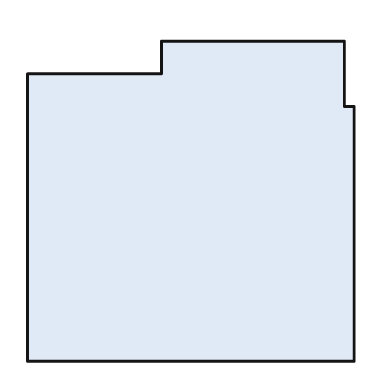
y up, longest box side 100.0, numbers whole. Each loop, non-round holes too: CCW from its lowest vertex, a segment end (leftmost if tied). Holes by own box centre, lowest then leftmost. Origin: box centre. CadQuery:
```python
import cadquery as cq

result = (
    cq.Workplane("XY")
    .moveTo(-50.0, -49.0)
    .lineTo(50.0, -49.0)
    .lineTo(50.0, 29.0)
    .lineTo(47.0, 29.0)
    .lineTo(47.0, 49.0)
    .lineTo(-9.0, 49.0)
    .lineTo(-9.0, 39.0)
    .lineTo(-50.0, 39.0)
    .close()
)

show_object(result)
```